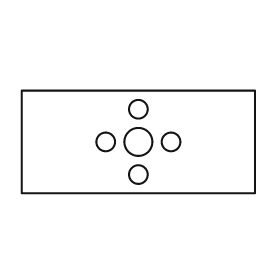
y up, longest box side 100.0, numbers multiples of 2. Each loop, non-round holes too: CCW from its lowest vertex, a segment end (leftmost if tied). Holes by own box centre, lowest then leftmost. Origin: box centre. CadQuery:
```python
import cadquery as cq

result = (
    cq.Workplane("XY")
    .moveTo(-50.0, -22.0)
    .lineTo(50.0, -22.0)
    .lineTo(50.0, 22.0)
    .lineTo(-50.0, 22.0)
    .close()
    .moveTo(0.0, -14.0)
    .circle(4.0)
    .moveTo(-14.0, 0.0)
    .circle(4.0)
    .moveTo(0.0, 0.0)
    .circle(6.0)
    .moveTo(14.0, 0.0)
    .circle(4.0)
    .moveTo(0.0, 14.0)
    .circle(4.0)
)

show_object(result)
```